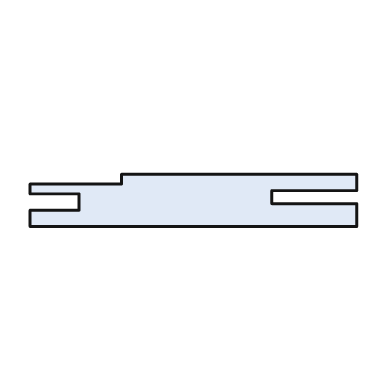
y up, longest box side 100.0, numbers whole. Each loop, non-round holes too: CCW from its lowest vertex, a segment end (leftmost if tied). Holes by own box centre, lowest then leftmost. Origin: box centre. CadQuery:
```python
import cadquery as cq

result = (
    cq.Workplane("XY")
    .moveTo(-50.0, -8.0)
    .lineTo(50.0, -8.0)
    .lineTo(50.0, -1.0)
    .lineTo(24.0, -1.0)
    .lineTo(24.0, 3.0)
    .lineTo(50.0, 3.0)
    .lineTo(50.0, 8.0)
    .lineTo(-22.0, 8.0)
    .lineTo(-22.0, 5.0)
    .lineTo(-50.0, 5.0)
    .lineTo(-50.0, 2.0)
    .lineTo(-35.0, 2.0)
    .lineTo(-35.0, -3.0)
    .lineTo(-50.0, -3.0)
    .close()
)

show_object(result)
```